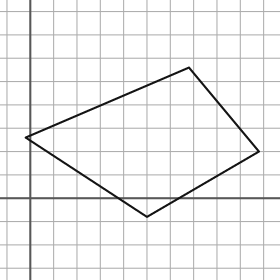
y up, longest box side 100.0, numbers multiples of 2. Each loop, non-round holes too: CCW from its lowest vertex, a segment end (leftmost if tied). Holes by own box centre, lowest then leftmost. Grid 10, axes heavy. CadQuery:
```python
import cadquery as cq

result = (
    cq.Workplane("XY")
    .moveTo(50.0, -8.0)
    .lineTo(98.0, 20.0)
    .lineTo(68.0, 56.0)
    .lineTo(-2.0, 26.0)
    .close()
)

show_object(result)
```